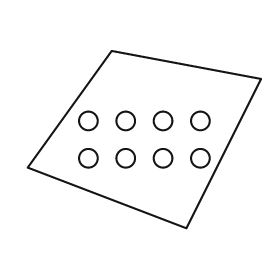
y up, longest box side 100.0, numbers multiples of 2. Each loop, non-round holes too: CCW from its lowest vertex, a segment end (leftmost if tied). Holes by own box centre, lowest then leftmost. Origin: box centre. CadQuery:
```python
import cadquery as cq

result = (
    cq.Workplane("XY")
    .moveTo(18.0, -38.0)
    .lineTo(50.0, 26.0)
    .lineTo(-14.0, 38.0)
    .lineTo(-50.0, -12.0)
    .close()
    .moveTo(-24.0, -8.0)
    .circle(4.0)
    .moveTo(-8.0, -8.0)
    .circle(4.0)
    .moveTo(8.0, -8.0)
    .circle(4.0)
    .moveTo(24.0, -8.0)
    .circle(4.0)
    .moveTo(-24.0, 8.0)
    .circle(4.0)
    .moveTo(-8.0, 8.0)
    .circle(4.0)
    .moveTo(8.0, 8.0)
    .circle(4.0)
    .moveTo(24.0, 8.0)
    .circle(4.0)
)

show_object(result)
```